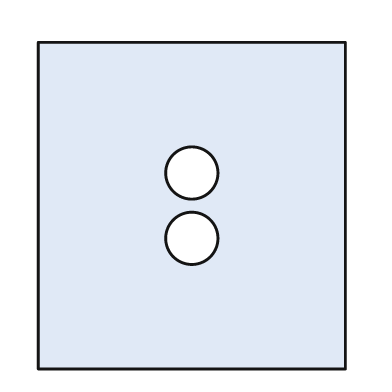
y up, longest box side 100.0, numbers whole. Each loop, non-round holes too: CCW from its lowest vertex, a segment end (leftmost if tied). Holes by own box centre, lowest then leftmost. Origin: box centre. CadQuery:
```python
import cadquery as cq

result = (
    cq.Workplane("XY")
    .moveTo(-47.0, -50.0)
    .lineTo(47.0, -50.0)
    .lineTo(47.0, 50.0)
    .lineTo(-47.0, 50.0)
    .close()
    .moveTo(0.0, -10.0)
    .circle(8.0)
    .moveTo(0.0, 10.0)
    .circle(8.0)
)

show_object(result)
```